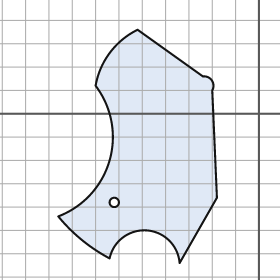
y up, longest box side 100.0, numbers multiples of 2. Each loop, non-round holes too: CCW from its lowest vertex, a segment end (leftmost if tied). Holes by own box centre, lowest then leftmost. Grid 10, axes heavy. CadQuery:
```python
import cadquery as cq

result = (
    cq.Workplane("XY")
    .moveTo(-34.0, -64.0)
    .lineTo(-18.0, -36.0)
    .lineTo(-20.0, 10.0)
    .threePointArc((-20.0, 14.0), (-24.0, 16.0))
    .lineTo(-52.0, 36.0)
    .threePointArc((-64.0, 26.0), (-70.0, 12.0))
    .threePointArc((-64.0, -20.0), (-86.0, -44.0))
    .threePointArc((-76.0, -54.0), (-64.0, -62.0))
    .threePointArc((-48.0, -50.0), (-34.0, -64.0))
    .close()
    .moveTo(-62.0, -38.0)
    .circle(2.0)
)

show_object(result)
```